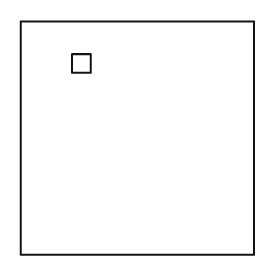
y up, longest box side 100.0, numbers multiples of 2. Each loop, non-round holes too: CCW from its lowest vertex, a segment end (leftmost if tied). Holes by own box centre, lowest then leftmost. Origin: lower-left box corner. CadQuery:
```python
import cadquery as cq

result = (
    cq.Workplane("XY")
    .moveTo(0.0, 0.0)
    .lineTo(100.0, 0.0)
    .lineTo(100.0, 100.0)
    .lineTo(0.0, 100.0)
    .close()
    .moveTo(22.0, 78.0)
    .lineTo(30.0, 78.0)
    .lineTo(30.0, 86.0)
    .lineTo(22.0, 86.0)
    .close()
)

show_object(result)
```